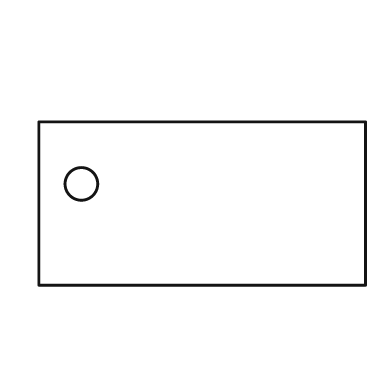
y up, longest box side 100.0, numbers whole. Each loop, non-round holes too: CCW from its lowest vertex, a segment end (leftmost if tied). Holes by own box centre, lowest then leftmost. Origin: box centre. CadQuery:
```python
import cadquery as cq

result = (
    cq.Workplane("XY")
    .moveTo(-50.0, -25.0)
    .lineTo(50.0, -25.0)
    .lineTo(50.0, 25.0)
    .lineTo(-50.0, 25.0)
    .close()
    .moveTo(-37.0, 6.0)
    .circle(5.0)
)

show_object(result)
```